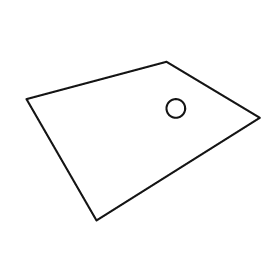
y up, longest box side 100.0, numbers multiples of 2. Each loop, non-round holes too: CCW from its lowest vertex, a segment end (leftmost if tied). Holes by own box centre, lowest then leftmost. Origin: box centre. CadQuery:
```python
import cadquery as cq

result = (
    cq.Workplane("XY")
    .moveTo(-20.0, -34.0)
    .lineTo(50.0, 10.0)
    .lineTo(10.0, 34.0)
    .lineTo(-50.0, 18.0)
    .close()
    .moveTo(14.0, 14.0)
    .circle(4.0)
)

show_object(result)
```